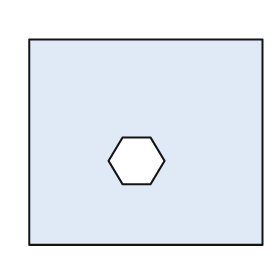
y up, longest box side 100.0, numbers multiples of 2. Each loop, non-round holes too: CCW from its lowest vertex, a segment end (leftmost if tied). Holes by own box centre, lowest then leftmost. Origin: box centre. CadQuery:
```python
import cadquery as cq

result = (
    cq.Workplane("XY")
    .moveTo(-50.0, -44.0)
    .lineTo(50.0, -44.0)
    .lineTo(50.0, 44.0)
    .lineTo(-50.0, 44.0)
    .close()
    .moveTo(-10.0, -18.0)
    .lineTo(2.0, -18.0)
    .lineTo(8.0, -8.0)
    .lineTo(2.0, 2.0)
    .lineTo(-10.0, 2.0)
    .lineTo(-16.0, -8.0)
    .close()
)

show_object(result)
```